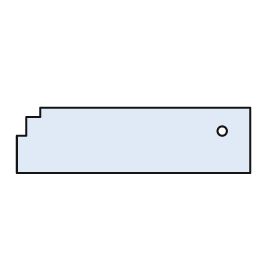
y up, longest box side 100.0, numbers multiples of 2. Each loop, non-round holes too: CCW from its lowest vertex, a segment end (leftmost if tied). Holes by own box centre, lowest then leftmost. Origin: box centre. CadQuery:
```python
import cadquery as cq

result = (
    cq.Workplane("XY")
    .moveTo(-50.0, -14.0)
    .lineTo(50.0, -14.0)
    .lineTo(50.0, 14.0)
    .lineTo(-40.0, 14.0)
    .lineTo(-40.0, 10.0)
    .lineTo(-46.0, 10.0)
    .lineTo(-46.0, 2.0)
    .lineTo(-50.0, 2.0)
    .close()
    .moveTo(38.0, 4.0)
    .circle(2.0)
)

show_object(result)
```